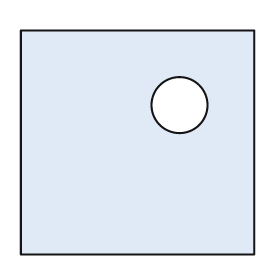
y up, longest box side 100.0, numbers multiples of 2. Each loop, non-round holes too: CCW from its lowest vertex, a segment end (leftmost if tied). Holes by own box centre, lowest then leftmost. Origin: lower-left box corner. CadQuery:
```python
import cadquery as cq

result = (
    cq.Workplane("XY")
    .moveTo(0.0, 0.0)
    .lineTo(100.0, 0.0)
    .lineTo(100.0, 96.0)
    .lineTo(0.0, 96.0)
    .close()
    .moveTo(68.0, 64.0)
    .circle(12.0)
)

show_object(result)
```